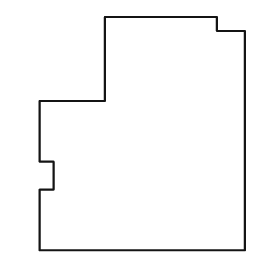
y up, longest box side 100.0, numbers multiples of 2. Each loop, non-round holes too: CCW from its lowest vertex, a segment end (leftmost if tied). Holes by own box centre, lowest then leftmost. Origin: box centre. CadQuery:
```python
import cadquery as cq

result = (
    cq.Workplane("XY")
    .moveTo(-44.0, -50.0)
    .lineTo(44.0, -50.0)
    .lineTo(44.0, 44.0)
    .lineTo(32.0, 44.0)
    .lineTo(32.0, 50.0)
    .lineTo(-16.0, 50.0)
    .lineTo(-16.0, 14.0)
    .lineTo(-44.0, 14.0)
    .lineTo(-44.0, -12.0)
    .lineTo(-38.0, -12.0)
    .lineTo(-38.0, -24.0)
    .lineTo(-44.0, -24.0)
    .close()
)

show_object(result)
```